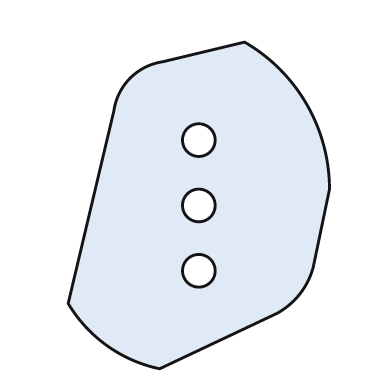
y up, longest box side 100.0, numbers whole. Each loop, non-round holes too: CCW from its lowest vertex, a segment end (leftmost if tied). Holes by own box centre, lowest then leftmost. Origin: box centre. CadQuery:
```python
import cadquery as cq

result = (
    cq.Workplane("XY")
    .moveTo(-12.0, -50.0)
    .lineTo(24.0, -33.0)
    .threePointArc((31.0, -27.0), (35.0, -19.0))
    .lineTo(40.0, 5.0)
    .threePointArc((33.0, 31.0), (14.0, 50.0))
    .lineTo(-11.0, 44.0)
    .threePointArc((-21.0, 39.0), (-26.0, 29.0))
    .lineTo(-40.0, -30.0)
    .threePointArc((-28.0, -43.0), (-12.0, -50.0))
    .close()
    .moveTo(0.0, -20.0)
    .circle(5.0)
    .moveTo(0.0, 0.0)
    .circle(5.0)
    .moveTo(0.0, 20.0)
    .circle(5.0)
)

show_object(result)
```